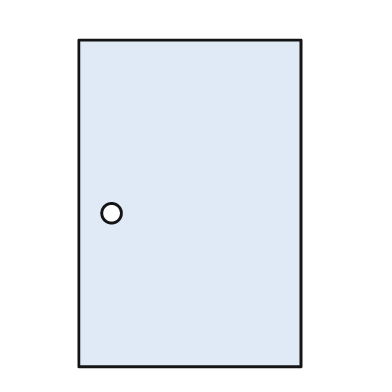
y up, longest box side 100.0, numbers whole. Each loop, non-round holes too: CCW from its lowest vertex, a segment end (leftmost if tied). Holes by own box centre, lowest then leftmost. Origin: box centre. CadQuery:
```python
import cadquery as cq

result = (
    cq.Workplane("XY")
    .moveTo(-34.0, -50.0)
    .lineTo(34.0, -50.0)
    .lineTo(34.0, 50.0)
    .lineTo(-34.0, 50.0)
    .close()
    .moveTo(-24.0, -3.0)
    .circle(3.0)
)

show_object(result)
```